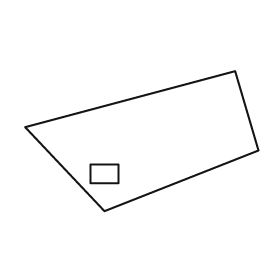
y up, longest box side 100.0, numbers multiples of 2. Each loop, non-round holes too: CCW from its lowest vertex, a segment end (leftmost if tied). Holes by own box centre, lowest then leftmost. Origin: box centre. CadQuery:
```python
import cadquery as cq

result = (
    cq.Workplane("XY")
    .moveTo(-16.0, -30.0)
    .lineTo(50.0, -4.0)
    .lineTo(40.0, 30.0)
    .lineTo(-50.0, 6.0)
    .close()
    .moveTo(-22.0, -18.0)
    .lineTo(-10.0, -18.0)
    .lineTo(-10.0, -10.0)
    .lineTo(-22.0, -10.0)
    .close()
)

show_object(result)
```